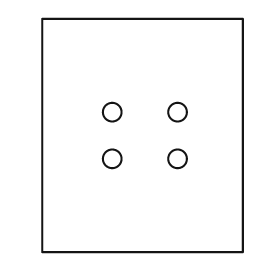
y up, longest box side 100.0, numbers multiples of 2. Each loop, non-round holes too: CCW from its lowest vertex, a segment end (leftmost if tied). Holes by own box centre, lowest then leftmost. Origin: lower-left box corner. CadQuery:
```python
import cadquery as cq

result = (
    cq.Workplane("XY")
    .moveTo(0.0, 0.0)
    .lineTo(86.0, 0.0)
    .lineTo(86.0, 100.0)
    .lineTo(0.0, 100.0)
    .close()
    .moveTo(30.0, 40.0)
    .circle(4.0)
    .moveTo(58.0, 40.0)
    .circle(4.0)
    .moveTo(30.0, 60.0)
    .circle(4.0)
    .moveTo(58.0, 60.0)
    .circle(4.0)
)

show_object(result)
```